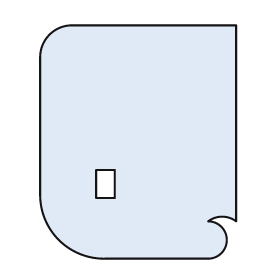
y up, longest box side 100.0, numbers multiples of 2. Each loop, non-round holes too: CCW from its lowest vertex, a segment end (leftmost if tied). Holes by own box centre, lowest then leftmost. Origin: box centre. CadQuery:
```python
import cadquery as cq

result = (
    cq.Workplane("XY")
    .moveTo(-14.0, -50.0)
    .lineTo(30.0, -50.0)
    .threePointArc((38.0, -42.0), (30.0, -34.0))
    .threePointArc((36.0, -32.0), (42.0, -34.0))
    .lineTo(42.0, 50.0)
    .lineTo(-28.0, 50.0)
    .threePointArc((-38.0, 46.0), (-42.0, 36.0))
    .lineTo(-42.0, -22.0)
    .threePointArc((-34.0, -42.0), (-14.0, -50.0))
    .close()
    .moveTo(-18.0, -24.0)
    .lineTo(-10.0, -24.0)
    .lineTo(-10.0, -12.0)
    .lineTo(-18.0, -12.0)
    .close()
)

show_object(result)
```